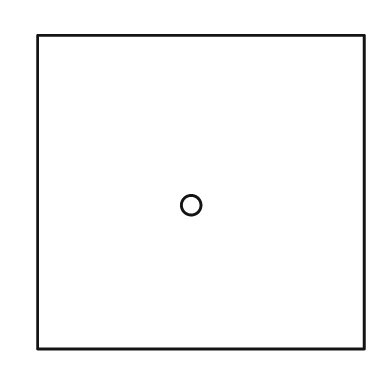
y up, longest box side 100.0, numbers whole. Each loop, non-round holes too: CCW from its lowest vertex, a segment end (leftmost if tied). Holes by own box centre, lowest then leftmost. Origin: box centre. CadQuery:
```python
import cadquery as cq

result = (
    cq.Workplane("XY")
    .moveTo(-50.0, -48.0)
    .lineTo(50.0, -48.0)
    .lineTo(50.0, 48.0)
    .lineTo(-50.0, 48.0)
    .close()
    .moveTo(-3.0, -4.0)
    .circle(3.0)
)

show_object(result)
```